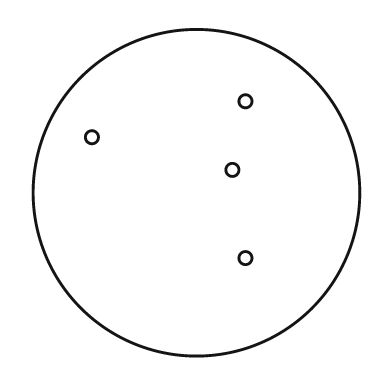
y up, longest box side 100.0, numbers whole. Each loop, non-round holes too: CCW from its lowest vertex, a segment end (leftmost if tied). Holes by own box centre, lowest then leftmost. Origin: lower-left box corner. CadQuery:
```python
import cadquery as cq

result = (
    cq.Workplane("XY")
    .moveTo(50.0, 50.0)
    .circle(50.0)
    .moveTo(65.0, 30.0)
    .circle(2.0)
    .moveTo(61.0, 57.0)
    .circle(2.0)
    .moveTo(18.0, 67.0)
    .circle(2.0)
    .moveTo(65.0, 78.0)
    .circle(2.0)
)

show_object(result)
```